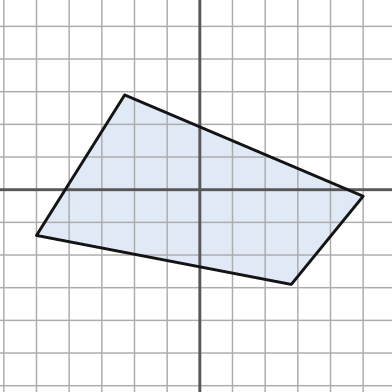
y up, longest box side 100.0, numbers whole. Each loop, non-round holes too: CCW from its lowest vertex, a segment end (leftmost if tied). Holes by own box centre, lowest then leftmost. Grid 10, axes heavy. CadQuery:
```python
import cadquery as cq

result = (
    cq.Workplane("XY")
    .moveTo(28.0, -29.0)
    .lineTo(50.0, -2.0)
    .lineTo(-23.0, 29.0)
    .lineTo(-50.0, -14.0)
    .close()
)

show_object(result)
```